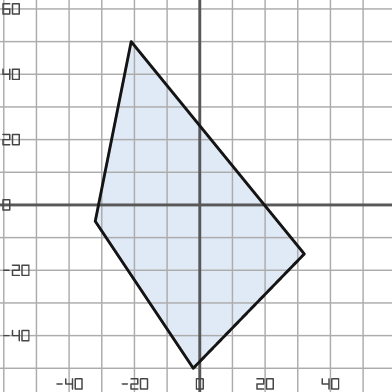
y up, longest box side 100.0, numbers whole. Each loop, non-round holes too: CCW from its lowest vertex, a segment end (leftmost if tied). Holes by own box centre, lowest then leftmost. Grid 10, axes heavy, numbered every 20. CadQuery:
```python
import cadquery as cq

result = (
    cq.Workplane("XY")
    .moveTo(-2.0, -50.0)
    .lineTo(32.0, -15.0)
    .lineTo(-21.0, 50.0)
    .lineTo(-32.0, -5.0)
    .close()
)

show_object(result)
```